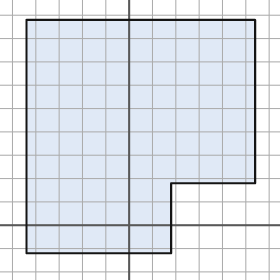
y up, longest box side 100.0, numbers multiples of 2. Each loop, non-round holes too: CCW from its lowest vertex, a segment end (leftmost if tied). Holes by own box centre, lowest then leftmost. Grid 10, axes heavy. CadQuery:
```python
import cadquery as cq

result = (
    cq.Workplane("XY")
    .moveTo(-44.0, -12.0)
    .lineTo(18.0, -12.0)
    .lineTo(18.0, 18.0)
    .lineTo(54.0, 18.0)
    .lineTo(54.0, 88.0)
    .lineTo(-44.0, 88.0)
    .close()
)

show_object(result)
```